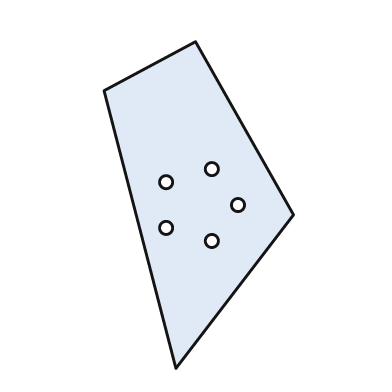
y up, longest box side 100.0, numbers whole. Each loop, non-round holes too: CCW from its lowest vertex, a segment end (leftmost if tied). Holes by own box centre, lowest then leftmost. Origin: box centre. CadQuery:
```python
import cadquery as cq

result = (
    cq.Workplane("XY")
    .moveTo(-7.0, -50.0)
    .lineTo(29.0, -3.0)
    .lineTo(-1.0, 50.0)
    .lineTo(-29.0, 35.0)
    .close()
    .moveTo(4.0, -11.0)
    .circle(2.0)
    .moveTo(-10.0, -7.0)
    .circle(2.0)
    .moveTo(12.0, 0.0)
    .circle(2.0)
    .moveTo(-10.0, 7.0)
    .circle(2.0)
    .moveTo(4.0, 11.0)
    .circle(2.0)
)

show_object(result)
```